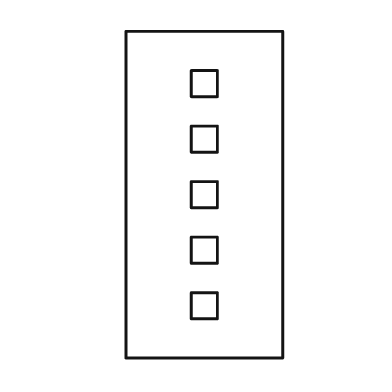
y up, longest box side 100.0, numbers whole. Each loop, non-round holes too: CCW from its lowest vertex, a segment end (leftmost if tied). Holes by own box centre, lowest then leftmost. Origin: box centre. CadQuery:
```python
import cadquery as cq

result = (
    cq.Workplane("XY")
    .moveTo(-24.0, -50.0)
    .lineTo(24.0, -50.0)
    .lineTo(24.0, 50.0)
    .lineTo(-24.0, 50.0)
    .close()
    .moveTo(-4.0, -38.0)
    .lineTo(4.0, -38.0)
    .lineTo(4.0, -30.0)
    .lineTo(-4.0, -30.0)
    .close()
    .moveTo(-4.0, -21.0)
    .lineTo(4.0, -21.0)
    .lineTo(4.0, -13.0)
    .lineTo(-4.0, -13.0)
    .close()
    .moveTo(-4.0, -4.0)
    .lineTo(4.0, -4.0)
    .lineTo(4.0, 4.0)
    .lineTo(-4.0, 4.0)
    .close()
    .moveTo(-4.0, 13.0)
    .lineTo(4.0, 13.0)
    .lineTo(4.0, 21.0)
    .lineTo(-4.0, 21.0)
    .close()
    .moveTo(-4.0, 30.0)
    .lineTo(4.0, 30.0)
    .lineTo(4.0, 38.0)
    .lineTo(-4.0, 38.0)
    .close()
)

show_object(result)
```